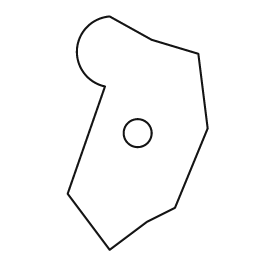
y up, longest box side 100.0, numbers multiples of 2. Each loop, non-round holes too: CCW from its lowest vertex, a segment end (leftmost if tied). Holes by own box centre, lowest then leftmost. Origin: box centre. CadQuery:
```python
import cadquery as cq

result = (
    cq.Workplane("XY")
    .moveTo(-12.0, -50.0)
    .lineTo(4.0, -38.0)
    .lineTo(16.0, -32.0)
    .lineTo(30.0, 2.0)
    .lineTo(26.0, 34.0)
    .lineTo(6.0, 40.0)
    .lineTo(-12.0, 50.0)
    .threePointArc((-26.0, 36.0), (-14.0, 20.0))
    .lineTo(-30.0, -26.0)
    .close()
    .moveTo(0.0, 0.0)
    .circle(6.0)
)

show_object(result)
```